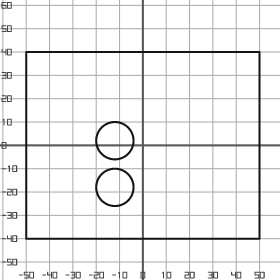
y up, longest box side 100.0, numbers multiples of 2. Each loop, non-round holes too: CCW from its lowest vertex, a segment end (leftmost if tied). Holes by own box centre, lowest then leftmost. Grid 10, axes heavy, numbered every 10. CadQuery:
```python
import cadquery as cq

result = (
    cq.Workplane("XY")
    .moveTo(-50.0, -40.0)
    .lineTo(50.0, -40.0)
    .lineTo(50.0, 40.0)
    .lineTo(-50.0, 40.0)
    .close()
    .moveTo(-12.0, -18.0)
    .circle(8.0)
    .moveTo(-12.0, 2.0)
    .circle(8.0)
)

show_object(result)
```